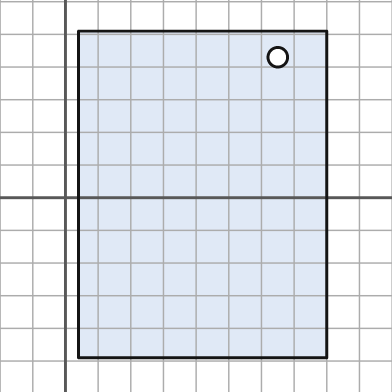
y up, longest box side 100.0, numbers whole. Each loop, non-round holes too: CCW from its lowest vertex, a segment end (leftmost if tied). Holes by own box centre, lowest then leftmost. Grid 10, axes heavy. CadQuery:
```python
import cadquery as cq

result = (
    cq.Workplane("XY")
    .moveTo(4.0, -49.0)
    .lineTo(80.0, -49.0)
    .lineTo(80.0, 51.0)
    .lineTo(4.0, 51.0)
    .close()
    .moveTo(65.0, 43.0)
    .circle(3.0)
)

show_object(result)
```